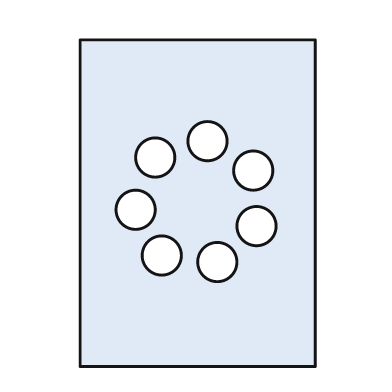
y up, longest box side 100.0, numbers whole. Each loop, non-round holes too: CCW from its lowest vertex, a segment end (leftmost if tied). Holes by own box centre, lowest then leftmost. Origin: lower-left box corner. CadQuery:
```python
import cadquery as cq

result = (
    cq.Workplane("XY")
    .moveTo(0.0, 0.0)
    .lineTo(72.0, 0.0)
    .lineTo(72.0, 100.0)
    .lineTo(0.0, 100.0)
    .close()
    .moveTo(42.0, 32.0)
    .circle(6.0)
    .moveTo(25.0, 34.0)
    .circle(6.0)
    .moveTo(54.0, 43.0)
    .circle(6.0)
    .moveTo(17.0, 48.0)
    .circle(6.0)
    .moveTo(53.0, 60.0)
    .circle(6.0)
    .moveTo(23.0, 64.0)
    .circle(6.0)
    .moveTo(39.0, 69.0)
    .circle(6.0)
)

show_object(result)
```